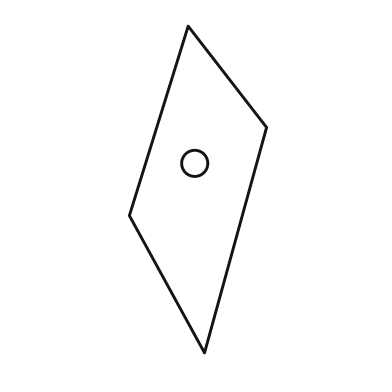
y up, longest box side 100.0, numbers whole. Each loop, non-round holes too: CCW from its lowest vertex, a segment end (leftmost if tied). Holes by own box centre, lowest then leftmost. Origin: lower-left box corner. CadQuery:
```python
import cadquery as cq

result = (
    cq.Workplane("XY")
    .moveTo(23.0, 0.0)
    .lineTo(42.0, 69.0)
    .lineTo(18.0, 100.0)
    .lineTo(0.0, 42.0)
    .close()
    .moveTo(20.0, 58.0)
    .circle(4.0)
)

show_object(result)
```